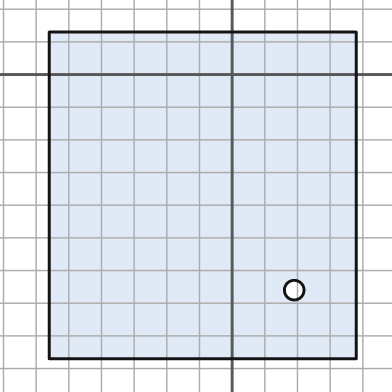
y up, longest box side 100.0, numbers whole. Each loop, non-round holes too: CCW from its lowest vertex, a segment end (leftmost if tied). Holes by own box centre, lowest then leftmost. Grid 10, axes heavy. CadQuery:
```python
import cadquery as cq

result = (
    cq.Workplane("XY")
    .moveTo(-56.0, -87.0)
    .lineTo(38.0, -87.0)
    .lineTo(38.0, 13.0)
    .lineTo(-56.0, 13.0)
    .close()
    .moveTo(19.0, -66.0)
    .circle(3.0)
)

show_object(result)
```